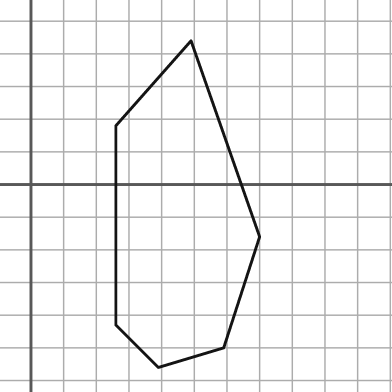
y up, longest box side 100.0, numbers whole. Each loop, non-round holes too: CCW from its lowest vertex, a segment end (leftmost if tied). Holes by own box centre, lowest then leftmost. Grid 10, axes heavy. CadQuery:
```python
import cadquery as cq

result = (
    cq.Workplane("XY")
    .moveTo(39.0, -56.0)
    .lineTo(59.0, -50.0)
    .lineTo(70.0, -16.0)
    .lineTo(49.0, 44.0)
    .lineTo(26.0, 18.0)
    .lineTo(26.0, -43.0)
    .close()
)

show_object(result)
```